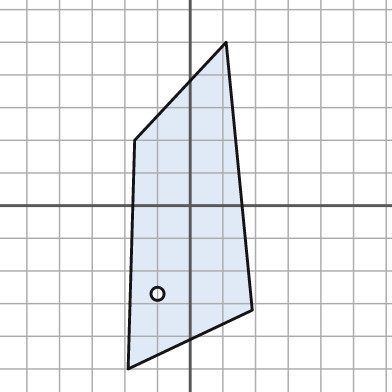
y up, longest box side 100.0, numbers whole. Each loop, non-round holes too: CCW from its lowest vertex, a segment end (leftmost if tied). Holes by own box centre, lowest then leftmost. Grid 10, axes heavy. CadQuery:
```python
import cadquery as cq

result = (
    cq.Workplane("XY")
    .moveTo(-19.0, -50.0)
    .lineTo(19.0, -32.0)
    .lineTo(11.0, 50.0)
    .lineTo(-17.0, 20.0)
    .close()
    .moveTo(-10.0, -27.0)
    .circle(2.0)
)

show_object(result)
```